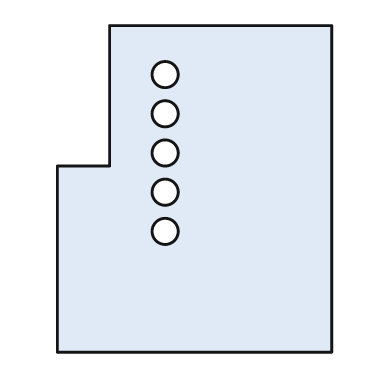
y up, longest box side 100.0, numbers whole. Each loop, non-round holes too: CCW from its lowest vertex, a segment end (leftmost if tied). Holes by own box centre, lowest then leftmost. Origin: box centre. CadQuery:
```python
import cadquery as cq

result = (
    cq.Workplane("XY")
    .moveTo(-42.0, -50.0)
    .lineTo(42.0, -50.0)
    .lineTo(42.0, 50.0)
    .lineTo(-26.0, 50.0)
    .lineTo(-26.0, 7.0)
    .lineTo(-42.0, 7.0)
    .close()
    .moveTo(-9.0, -13.0)
    .circle(4.0)
    .moveTo(-9.0, -1.0)
    .circle(4.0)
    .moveTo(-9.0, 11.0)
    .circle(4.0)
    .moveTo(-9.0, 23.0)
    .circle(4.0)
    .moveTo(-9.0, 35.0)
    .circle(4.0)
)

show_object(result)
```